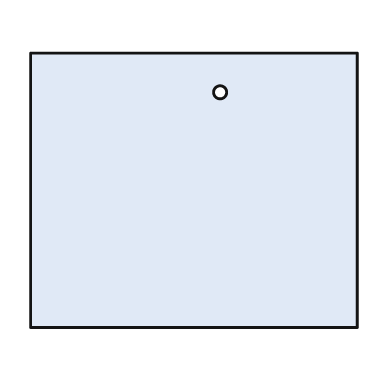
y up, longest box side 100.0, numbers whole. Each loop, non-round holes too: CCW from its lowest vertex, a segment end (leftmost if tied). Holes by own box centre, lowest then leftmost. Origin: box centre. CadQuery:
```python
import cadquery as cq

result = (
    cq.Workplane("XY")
    .moveTo(-50.0, -42.0)
    .lineTo(50.0, -42.0)
    .lineTo(50.0, 42.0)
    .lineTo(-50.0, 42.0)
    .close()
    .moveTo(8.0, 30.0)
    .circle(2.0)
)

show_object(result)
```